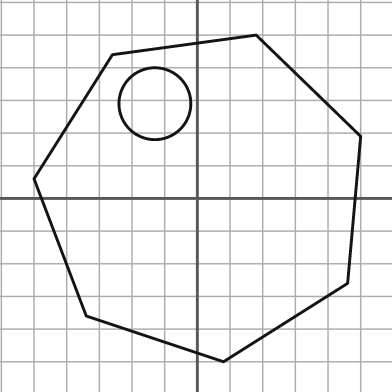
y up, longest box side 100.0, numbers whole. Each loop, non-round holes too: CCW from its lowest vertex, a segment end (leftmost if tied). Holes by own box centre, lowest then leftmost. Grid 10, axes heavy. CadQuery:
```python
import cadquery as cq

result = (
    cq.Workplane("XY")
    .moveTo(8.0, -50.0)
    .lineTo(46.0, -26.0)
    .lineTo(50.0, 19.0)
    .lineTo(18.0, 50.0)
    .lineTo(-26.0, 44.0)
    .lineTo(-50.0, 6.0)
    .lineTo(-34.0, -36.0)
    .close()
    .moveTo(-13.0, 29.0)
    .circle(11.0)
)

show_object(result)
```